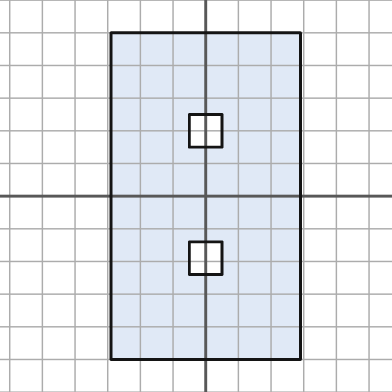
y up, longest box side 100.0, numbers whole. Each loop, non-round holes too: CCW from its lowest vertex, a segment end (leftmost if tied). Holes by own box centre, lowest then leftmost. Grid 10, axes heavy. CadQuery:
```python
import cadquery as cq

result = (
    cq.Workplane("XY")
    .moveTo(-29.0, -50.0)
    .lineTo(29.0, -50.0)
    .lineTo(29.0, 50.0)
    .lineTo(-29.0, 50.0)
    .close()
    .moveTo(-5.0, -24.0)
    .lineTo(5.0, -24.0)
    .lineTo(5.0, -14.0)
    .lineTo(-5.0, -14.0)
    .close()
    .moveTo(-5.0, 15.0)
    .lineTo(5.0, 15.0)
    .lineTo(5.0, 25.0)
    .lineTo(-5.0, 25.0)
    .close()
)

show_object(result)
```